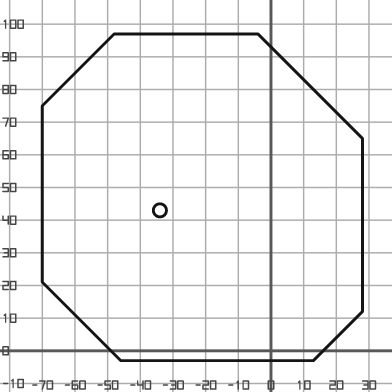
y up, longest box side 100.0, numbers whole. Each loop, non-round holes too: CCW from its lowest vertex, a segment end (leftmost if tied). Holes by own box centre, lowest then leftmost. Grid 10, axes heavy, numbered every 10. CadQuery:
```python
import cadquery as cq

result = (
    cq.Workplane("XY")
    .moveTo(-46.0, -3.0)
    .lineTo(13.0, -3.0)
    .lineTo(28.0, 12.0)
    .lineTo(28.0, 65.0)
    .lineTo(-4.0, 97.0)
    .lineTo(-48.0, 97.0)
    .lineTo(-70.0, 75.0)
    .lineTo(-70.0, 21.0)
    .close()
    .moveTo(-34.0, 43.0)
    .circle(2.0)
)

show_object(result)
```